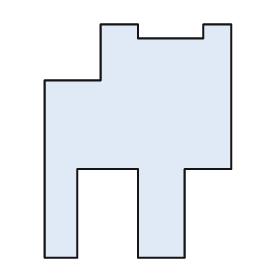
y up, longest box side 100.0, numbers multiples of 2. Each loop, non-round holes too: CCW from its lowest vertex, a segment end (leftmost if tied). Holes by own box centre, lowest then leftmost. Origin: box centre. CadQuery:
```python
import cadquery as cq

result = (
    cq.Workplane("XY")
    .moveTo(-40.0, -50.0)
    .lineTo(-26.0, -50.0)
    .lineTo(-26.0, -12.0)
    .lineTo(0.0, -12.0)
    .lineTo(0.0, -50.0)
    .lineTo(20.0, -50.0)
    .lineTo(20.0, -12.0)
    .lineTo(40.0, -12.0)
    .lineTo(40.0, 50.0)
    .lineTo(28.0, 50.0)
    .lineTo(28.0, 44.0)
    .lineTo(0.0, 44.0)
    .lineTo(0.0, 50.0)
    .lineTo(-16.0, 50.0)
    .lineTo(-16.0, 26.0)
    .lineTo(-40.0, 26.0)
    .close()
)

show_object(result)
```